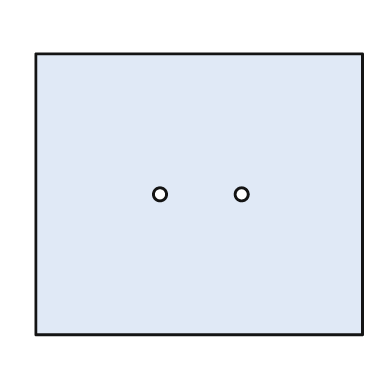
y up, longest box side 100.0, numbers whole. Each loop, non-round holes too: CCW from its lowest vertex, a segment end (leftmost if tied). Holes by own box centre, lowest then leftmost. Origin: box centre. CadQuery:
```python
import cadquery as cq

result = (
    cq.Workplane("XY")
    .moveTo(-50.0, -43.0)
    .lineTo(50.0, -43.0)
    .lineTo(50.0, 43.0)
    .lineTo(-50.0, 43.0)
    .close()
    .moveTo(-12.0, 0.0)
    .circle(2.0)
    .moveTo(13.0, 0.0)
    .circle(2.0)
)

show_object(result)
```